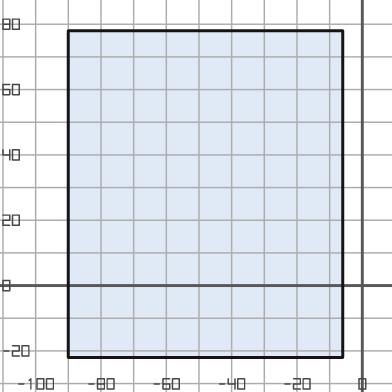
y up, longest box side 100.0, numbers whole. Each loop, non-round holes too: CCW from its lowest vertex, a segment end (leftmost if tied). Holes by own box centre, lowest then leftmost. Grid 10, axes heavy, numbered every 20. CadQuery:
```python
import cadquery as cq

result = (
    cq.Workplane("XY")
    .moveTo(-90.0, -22.0)
    .lineTo(-6.0, -22.0)
    .lineTo(-6.0, 78.0)
    .lineTo(-90.0, 78.0)
    .close()
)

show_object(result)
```